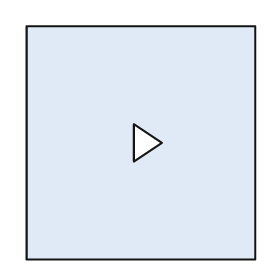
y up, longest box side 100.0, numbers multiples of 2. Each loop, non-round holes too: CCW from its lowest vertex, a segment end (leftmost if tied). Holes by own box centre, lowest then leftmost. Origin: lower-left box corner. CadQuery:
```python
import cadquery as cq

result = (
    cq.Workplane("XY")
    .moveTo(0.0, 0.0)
    .lineTo(98.0, 0.0)
    .lineTo(98.0, 100.0)
    .lineTo(0.0, 100.0)
    .close()
    .moveTo(46.0, 42.0)
    .lineTo(58.0, 50.0)
    .lineTo(46.0, 58.0)
    .close()
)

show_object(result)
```